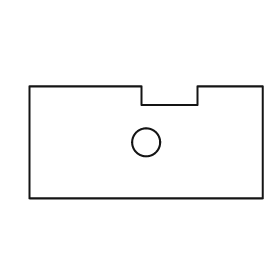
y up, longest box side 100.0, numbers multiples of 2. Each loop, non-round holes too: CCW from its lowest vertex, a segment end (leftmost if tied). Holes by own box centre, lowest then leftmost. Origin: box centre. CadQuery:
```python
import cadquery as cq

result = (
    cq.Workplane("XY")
    .moveTo(-50.0, -24.0)
    .lineTo(50.0, -24.0)
    .lineTo(50.0, 24.0)
    .lineTo(22.0, 24.0)
    .lineTo(22.0, 16.0)
    .lineTo(-2.0, 16.0)
    .lineTo(-2.0, 24.0)
    .lineTo(-50.0, 24.0)
    .close()
    .moveTo(0.0, 0.0)
    .circle(6.0)
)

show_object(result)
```